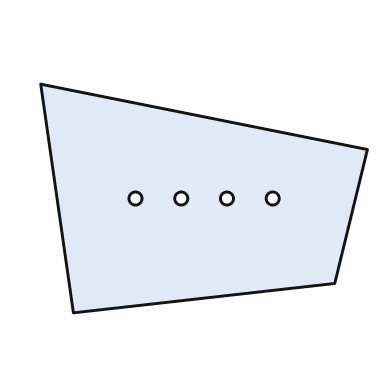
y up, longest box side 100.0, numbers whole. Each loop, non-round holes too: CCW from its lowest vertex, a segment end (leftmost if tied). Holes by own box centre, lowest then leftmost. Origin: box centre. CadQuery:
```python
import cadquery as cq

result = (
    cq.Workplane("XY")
    .moveTo(-40.0, -35.0)
    .lineTo(40.0, -26.0)
    .lineTo(50.0, 15.0)
    .lineTo(-50.0, 35.0)
    .close()
    .moveTo(-21.0, 0.0)
    .circle(2.0)
    .moveTo(-7.0, 0.0)
    .circle(2.0)
    .moveTo(7.0, 0.0)
    .circle(2.0)
    .moveTo(21.0, 0.0)
    .circle(2.0)
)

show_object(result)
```